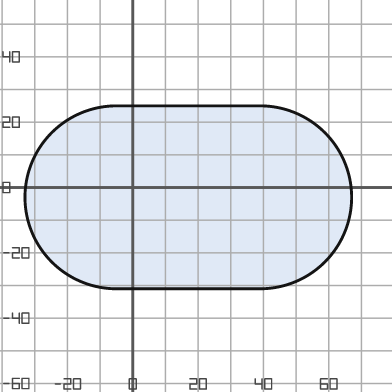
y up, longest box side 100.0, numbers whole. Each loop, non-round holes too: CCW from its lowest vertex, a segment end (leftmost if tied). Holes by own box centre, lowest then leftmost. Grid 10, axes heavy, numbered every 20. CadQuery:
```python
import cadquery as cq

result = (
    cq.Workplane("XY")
    .moveTo(-5.0, -31.0)
    .lineTo(39.0, -31.0)
    .threePointArc((67.0, -3.0), (39.0, 25.0))
    .lineTo(-5.0, 25.0)
    .threePointArc((-33.0, -3.0), (-5.0, -31.0))
    .close()
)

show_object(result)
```